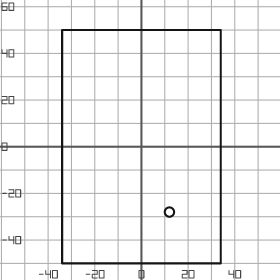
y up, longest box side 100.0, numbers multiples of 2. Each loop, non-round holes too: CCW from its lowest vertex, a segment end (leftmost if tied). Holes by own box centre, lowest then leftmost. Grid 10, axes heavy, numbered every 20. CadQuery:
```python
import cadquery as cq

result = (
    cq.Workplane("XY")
    .moveTo(-34.0, -50.0)
    .lineTo(34.0, -50.0)
    .lineTo(34.0, 50.0)
    .lineTo(-34.0, 50.0)
    .close()
    .moveTo(12.0, -28.0)
    .circle(2.0)
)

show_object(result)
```